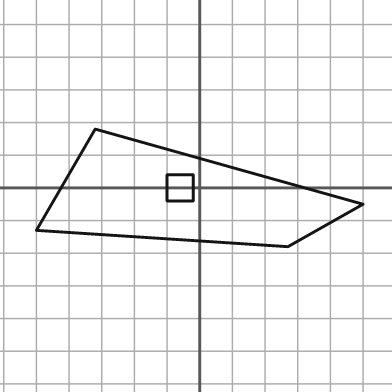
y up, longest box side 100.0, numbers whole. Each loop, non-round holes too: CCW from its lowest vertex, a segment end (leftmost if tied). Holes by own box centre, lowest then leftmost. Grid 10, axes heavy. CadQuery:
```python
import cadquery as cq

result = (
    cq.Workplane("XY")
    .moveTo(27.0, -18.0)
    .lineTo(50.0, -5.0)
    .lineTo(-32.0, 18.0)
    .lineTo(-50.0, -13.0)
    .close()
    .moveTo(-10.0, -4.0)
    .lineTo(-2.0, -4.0)
    .lineTo(-2.0, 4.0)
    .lineTo(-10.0, 4.0)
    .close()
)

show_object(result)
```